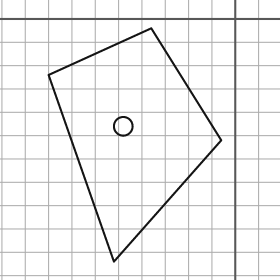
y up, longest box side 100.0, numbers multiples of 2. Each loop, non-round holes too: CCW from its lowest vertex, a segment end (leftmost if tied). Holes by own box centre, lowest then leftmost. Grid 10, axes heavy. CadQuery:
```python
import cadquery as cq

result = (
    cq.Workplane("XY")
    .moveTo(-52.0, -104.0)
    .lineTo(-6.0, -52.0)
    .lineTo(-36.0, -4.0)
    .lineTo(-80.0, -24.0)
    .close()
    .moveTo(-48.0, -46.0)
    .circle(4.0)
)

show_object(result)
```